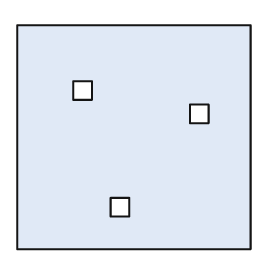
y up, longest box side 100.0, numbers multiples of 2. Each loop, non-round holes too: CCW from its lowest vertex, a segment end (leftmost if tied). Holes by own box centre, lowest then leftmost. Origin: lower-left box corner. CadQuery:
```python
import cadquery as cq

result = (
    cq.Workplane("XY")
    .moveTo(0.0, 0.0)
    .lineTo(100.0, 0.0)
    .lineTo(100.0, 96.0)
    .lineTo(0.0, 96.0)
    .close()
    .moveTo(40.0, 14.0)
    .lineTo(48.0, 14.0)
    .lineTo(48.0, 22.0)
    .lineTo(40.0, 22.0)
    .close()
    .moveTo(74.0, 54.0)
    .lineTo(82.0, 54.0)
    .lineTo(82.0, 62.0)
    .lineTo(74.0, 62.0)
    .close()
    .moveTo(24.0, 64.0)
    .lineTo(32.0, 64.0)
    .lineTo(32.0, 72.0)
    .lineTo(24.0, 72.0)
    .close()
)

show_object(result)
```